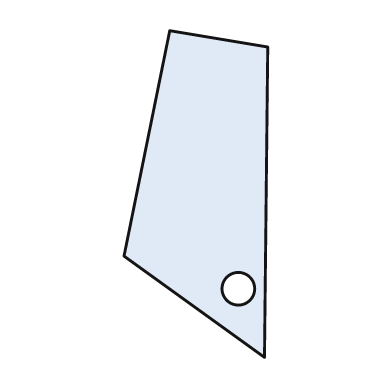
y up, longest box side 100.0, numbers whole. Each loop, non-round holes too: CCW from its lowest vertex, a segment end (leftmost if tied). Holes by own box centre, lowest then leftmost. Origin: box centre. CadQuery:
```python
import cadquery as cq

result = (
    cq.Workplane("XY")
    .moveTo(21.0, -50.0)
    .lineTo(22.0, 45.0)
    .lineTo(-8.0, 50.0)
    .lineTo(-22.0, -19.0)
    .close()
    .moveTo(13.0, -29.0)
    .circle(5.0)
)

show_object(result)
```